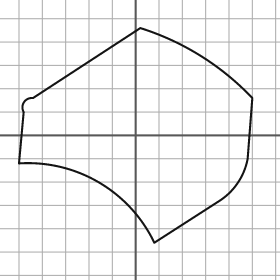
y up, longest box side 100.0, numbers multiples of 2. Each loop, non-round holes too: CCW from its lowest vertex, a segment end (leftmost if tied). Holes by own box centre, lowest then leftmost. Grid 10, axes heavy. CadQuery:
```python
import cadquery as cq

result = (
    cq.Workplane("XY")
    .moveTo(8.0, -46.0)
    .lineTo(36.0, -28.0)
    .threePointArc((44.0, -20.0), (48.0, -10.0))
    .lineTo(50.0, 16.0)
    .threePointArc((28.0, 34.0), (2.0, 46.0))
    .lineTo(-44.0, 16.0)
    .threePointArc((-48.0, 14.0), (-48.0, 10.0))
    .lineTo(-50.0, -12.0)
    .threePointArc((-16.0, -20.0), (8.0, -46.0))
    .close()
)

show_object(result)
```